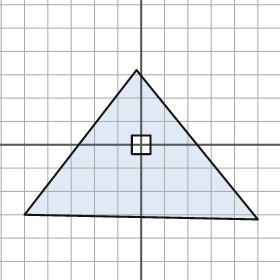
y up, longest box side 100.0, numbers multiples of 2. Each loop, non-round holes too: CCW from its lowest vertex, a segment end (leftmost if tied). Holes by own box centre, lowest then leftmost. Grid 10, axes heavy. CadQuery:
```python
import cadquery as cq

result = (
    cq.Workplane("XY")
    .moveTo(50.0, -32.0)
    .lineTo(-2.0, 32.0)
    .lineTo(-50.0, -30.0)
    .close()
    .moveTo(-4.0, -4.0)
    .lineTo(4.0, -4.0)
    .lineTo(4.0, 4.0)
    .lineTo(-4.0, 4.0)
    .close()
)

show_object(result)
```